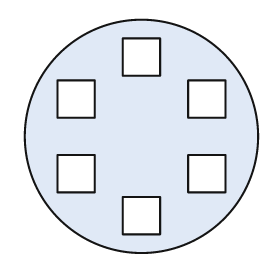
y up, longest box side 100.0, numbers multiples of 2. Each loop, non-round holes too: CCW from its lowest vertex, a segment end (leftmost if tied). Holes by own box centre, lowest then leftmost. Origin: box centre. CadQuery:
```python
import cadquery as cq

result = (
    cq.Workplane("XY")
    .moveTo(0.0, 0.0)
    .circle(50.0)
    .moveTo(-8.0, -42.0)
    .lineTo(8.0, -42.0)
    .lineTo(8.0, -26.0)
    .lineTo(-8.0, -26.0)
    .close()
    .moveTo(-36.0, -24.0)
    .lineTo(-20.0, -24.0)
    .lineTo(-20.0, -8.0)
    .lineTo(-36.0, -8.0)
    .close()
    .moveTo(20.0, -24.0)
    .lineTo(36.0, -24.0)
    .lineTo(36.0, -8.0)
    .lineTo(20.0, -8.0)
    .close()
    .moveTo(-36.0, 8.0)
    .lineTo(-20.0, 8.0)
    .lineTo(-20.0, 24.0)
    .lineTo(-36.0, 24.0)
    .close()
    .moveTo(20.0, 8.0)
    .lineTo(36.0, 8.0)
    .lineTo(36.0, 24.0)
    .lineTo(20.0, 24.0)
    .close()
    .moveTo(-8.0, 26.0)
    .lineTo(8.0, 26.0)
    .lineTo(8.0, 42.0)
    .lineTo(-8.0, 42.0)
    .close()
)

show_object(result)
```